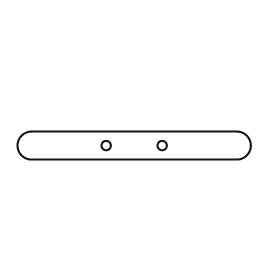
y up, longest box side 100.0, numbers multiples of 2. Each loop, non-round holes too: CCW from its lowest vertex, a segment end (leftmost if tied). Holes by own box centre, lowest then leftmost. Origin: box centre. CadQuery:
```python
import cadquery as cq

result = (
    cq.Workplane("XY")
    .moveTo(-44.0, -6.0)
    .lineTo(44.0, -6.0)
    .threePointArc((50.0, 0.0), (44.0, 6.0))
    .lineTo(-44.0, 6.0)
    .threePointArc((-50.0, 0.0), (-44.0, -6.0))
    .close()
    .moveTo(-12.0, 0.0)
    .circle(2.0)
    .moveTo(12.0, 0.0)
    .circle(2.0)
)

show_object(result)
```